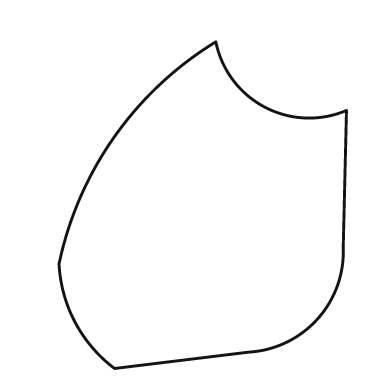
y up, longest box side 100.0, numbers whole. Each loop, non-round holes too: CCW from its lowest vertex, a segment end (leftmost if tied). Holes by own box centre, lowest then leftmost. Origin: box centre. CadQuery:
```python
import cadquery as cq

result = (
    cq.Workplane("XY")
    .moveTo(-27.0, -50.0)
    .lineTo(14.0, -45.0)
    .threePointArc((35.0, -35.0), (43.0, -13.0))
    .lineTo(44.0, 29.0)
    .threePointArc((19.0, 30.0), (4.0, 50.0))
    .threePointArc((-27.0, 21.0), (-44.0, -18.0))
    .threePointArc((-39.0, -36.0), (-27.0, -50.0))
    .close()
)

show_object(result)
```